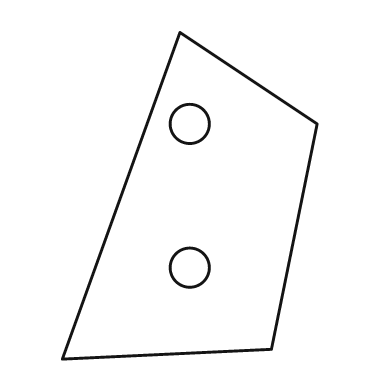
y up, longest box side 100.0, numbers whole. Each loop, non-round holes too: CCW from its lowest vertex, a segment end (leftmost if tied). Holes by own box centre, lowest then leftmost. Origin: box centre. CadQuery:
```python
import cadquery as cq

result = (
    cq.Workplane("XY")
    .moveTo(-39.0, -50.0)
    .lineTo(25.0, -47.0)
    .lineTo(39.0, 22.0)
    .lineTo(-3.0, 50.0)
    .close()
    .moveTo(0.0, -22.0)
    .circle(6.0)
    .moveTo(0.0, 22.0)
    .circle(6.0)
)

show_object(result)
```